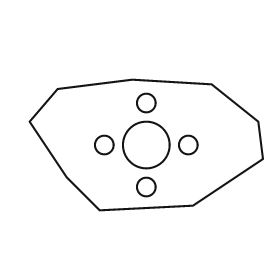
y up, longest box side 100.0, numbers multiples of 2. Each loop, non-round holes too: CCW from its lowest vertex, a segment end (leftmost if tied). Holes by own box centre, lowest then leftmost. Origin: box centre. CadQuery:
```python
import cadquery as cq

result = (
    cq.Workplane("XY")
    .moveTo(-20.0, -28.0)
    .lineTo(20.0, -26.0)
    .lineTo(50.0, -6.0)
    .lineTo(48.0, 10.0)
    .lineTo(28.0, 26.0)
    .lineTo(-6.0, 28.0)
    .lineTo(-38.0, 24.0)
    .lineTo(-50.0, 10.0)
    .lineTo(-34.0, -14.0)
    .close()
    .moveTo(0.0, -18.0)
    .circle(4.0)
    .moveTo(-18.0, 0.0)
    .circle(4.0)
    .moveTo(0.0, 0.0)
    .circle(10.0)
    .moveTo(18.0, 0.0)
    .circle(4.0)
    .moveTo(0.0, 18.0)
    .circle(4.0)
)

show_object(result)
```